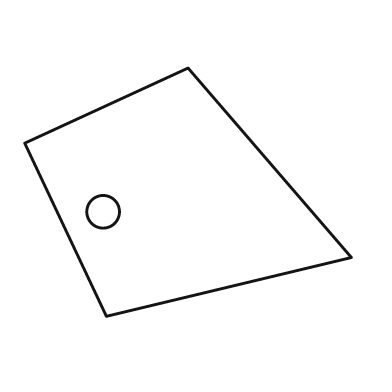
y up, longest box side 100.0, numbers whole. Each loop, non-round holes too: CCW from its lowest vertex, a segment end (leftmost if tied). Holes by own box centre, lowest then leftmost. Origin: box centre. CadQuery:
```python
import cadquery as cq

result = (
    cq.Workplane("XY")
    .moveTo(-25.0, -38.0)
    .lineTo(50.0, -20.0)
    .lineTo(0.0, 38.0)
    .lineTo(-50.0, 15.0)
    .close()
    .moveTo(-26.0, -6.0)
    .circle(5.0)
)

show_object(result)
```